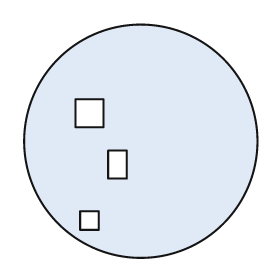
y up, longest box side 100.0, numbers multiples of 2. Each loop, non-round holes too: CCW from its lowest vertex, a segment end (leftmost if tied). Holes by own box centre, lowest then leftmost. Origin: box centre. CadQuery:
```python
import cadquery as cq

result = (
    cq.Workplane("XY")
    .moveTo(0.0, 0.0)
    .circle(50.0)
    .moveTo(-26.0, -38.0)
    .lineTo(-18.0, -38.0)
    .lineTo(-18.0, -30.0)
    .lineTo(-26.0, -30.0)
    .close()
    .moveTo(-14.0, -16.0)
    .lineTo(-6.0, -16.0)
    .lineTo(-6.0, -4.0)
    .lineTo(-14.0, -4.0)
    .close()
    .moveTo(-28.0, 6.0)
    .lineTo(-16.0, 6.0)
    .lineTo(-16.0, 18.0)
    .lineTo(-28.0, 18.0)
    .close()
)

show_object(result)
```